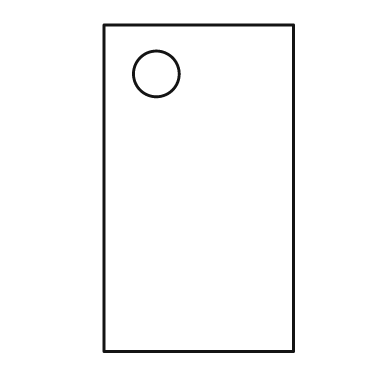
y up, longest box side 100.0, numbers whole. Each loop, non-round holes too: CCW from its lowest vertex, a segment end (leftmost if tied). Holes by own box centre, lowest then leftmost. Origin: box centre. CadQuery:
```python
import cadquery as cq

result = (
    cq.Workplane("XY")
    .moveTo(-29.0, -50.0)
    .lineTo(29.0, -50.0)
    .lineTo(29.0, 50.0)
    .lineTo(-29.0, 50.0)
    .close()
    .moveTo(-13.0, 35.0)
    .circle(7.0)
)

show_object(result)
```